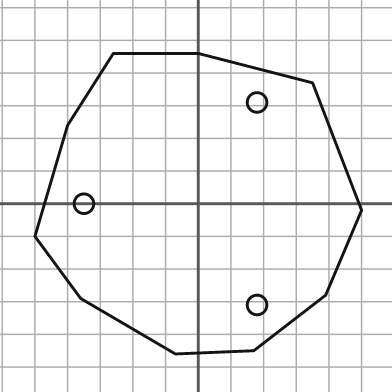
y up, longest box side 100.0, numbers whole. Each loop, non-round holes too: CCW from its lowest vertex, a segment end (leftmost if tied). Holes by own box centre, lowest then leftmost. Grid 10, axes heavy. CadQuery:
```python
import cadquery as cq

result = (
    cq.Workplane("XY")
    .moveTo(-7.0, -46.0)
    .lineTo(17.0, -45.0)
    .lineTo(39.0, -28.0)
    .lineTo(50.0, -2.0)
    .lineTo(35.0, 37.0)
    .lineTo(0.0, 46.0)
    .lineTo(-26.0, 46.0)
    .lineTo(-40.0, 24.0)
    .lineTo(-50.0, -10.0)
    .lineTo(-36.0, -29.0)
    .close()
    .moveTo(18.0, -31.0)
    .circle(3.0)
    .moveTo(-35.0, 0.0)
    .circle(3.0)
    .moveTo(18.0, 31.0)
    .circle(3.0)
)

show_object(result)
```